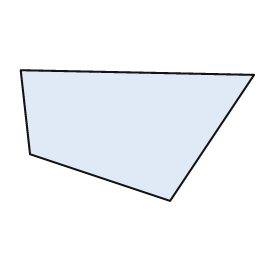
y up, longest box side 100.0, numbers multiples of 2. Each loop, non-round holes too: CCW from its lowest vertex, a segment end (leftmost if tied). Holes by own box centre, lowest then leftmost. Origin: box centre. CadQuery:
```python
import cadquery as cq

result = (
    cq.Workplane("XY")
    .moveTo(14.0, -28.0)
    .lineTo(50.0, 26.0)
    .lineTo(-50.0, 28.0)
    .lineTo(-46.0, -8.0)
    .close()
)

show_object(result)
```